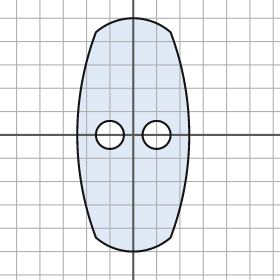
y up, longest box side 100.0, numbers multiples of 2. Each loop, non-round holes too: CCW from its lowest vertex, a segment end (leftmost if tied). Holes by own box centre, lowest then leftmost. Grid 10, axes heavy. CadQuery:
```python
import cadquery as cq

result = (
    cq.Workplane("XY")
    .moveTo(-16.0, -44.0)
    .threePointArc((0.0, -50.0), (16.0, -44.0))
    .threePointArc((24.0, 0.0), (16.0, 44.0))
    .threePointArc((0.0, 50.0), (-16.0, 44.0))
    .threePointArc((-24.0, 0.0), (-16.0, -44.0))
    .close()
    .moveTo(-10.0, 0.0)
    .circle(6.0)
    .moveTo(10.0, 0.0)
    .circle(6.0)
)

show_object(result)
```